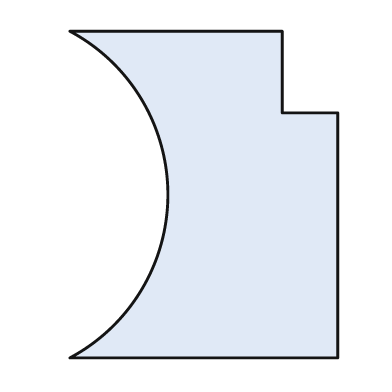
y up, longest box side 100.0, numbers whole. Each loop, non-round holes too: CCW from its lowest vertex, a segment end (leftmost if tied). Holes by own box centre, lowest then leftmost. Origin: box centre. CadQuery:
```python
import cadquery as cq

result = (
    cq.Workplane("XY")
    .moveTo(-41.0, -50.0)
    .lineTo(41.0, -50.0)
    .lineTo(41.0, 25.0)
    .lineTo(24.0, 25.0)
    .lineTo(24.0, 50.0)
    .lineTo(-41.0, 50.0)
    .threePointArc((-11.0, 0.0), (-41.0, -50.0))
    .close()
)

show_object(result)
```